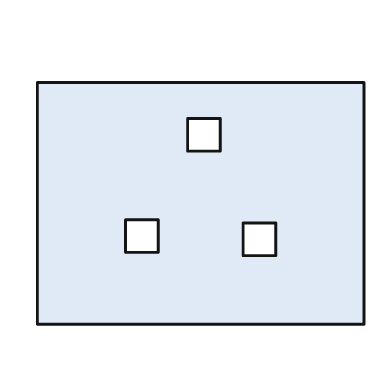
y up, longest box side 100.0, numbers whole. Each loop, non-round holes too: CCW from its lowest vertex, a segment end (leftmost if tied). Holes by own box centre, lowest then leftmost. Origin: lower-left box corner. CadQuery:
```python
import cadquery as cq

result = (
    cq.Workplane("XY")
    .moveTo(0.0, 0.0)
    .lineTo(100.0, 0.0)
    .lineTo(100.0, 74.0)
    .lineTo(0.0, 74.0)
    .close()
    .moveTo(63.0, 21.0)
    .lineTo(73.0, 21.0)
    .lineTo(73.0, 31.0)
    .lineTo(63.0, 31.0)
    .close()
    .moveTo(27.0, 22.0)
    .lineTo(37.0, 22.0)
    .lineTo(37.0, 32.0)
    .lineTo(27.0, 32.0)
    .close()
    .moveTo(46.0, 53.0)
    .lineTo(56.0, 53.0)
    .lineTo(56.0, 63.0)
    .lineTo(46.0, 63.0)
    .close()
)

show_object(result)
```